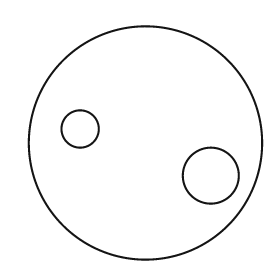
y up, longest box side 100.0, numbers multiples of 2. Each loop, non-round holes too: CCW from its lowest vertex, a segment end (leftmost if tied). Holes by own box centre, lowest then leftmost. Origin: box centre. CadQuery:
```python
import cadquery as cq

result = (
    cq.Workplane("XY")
    .moveTo(0.0, 0.0)
    .circle(50.0)
    .moveTo(28.0, -14.0)
    .circle(12.0)
    .moveTo(-28.0, 6.0)
    .circle(8.0)
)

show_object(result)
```